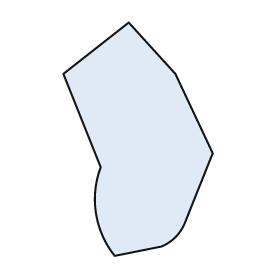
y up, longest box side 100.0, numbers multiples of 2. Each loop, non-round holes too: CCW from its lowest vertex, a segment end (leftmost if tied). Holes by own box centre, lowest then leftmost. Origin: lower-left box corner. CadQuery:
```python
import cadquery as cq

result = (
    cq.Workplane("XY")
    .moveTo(22.0, 0.0)
    .lineTo(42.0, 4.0)
    .threePointArc((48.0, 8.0), (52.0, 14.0))
    .lineTo(64.0, 44.0)
    .lineTo(48.0, 78.0)
    .lineTo(28.0, 100.0)
    .lineTo(0.0, 78.0)
    .lineTo(16.0, 38.0)
    .threePointArc((14.0, 18.0), (22.0, 0.0))
    .close()
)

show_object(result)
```